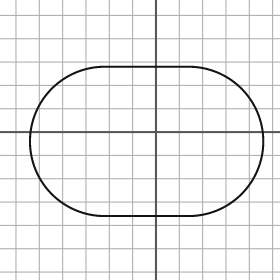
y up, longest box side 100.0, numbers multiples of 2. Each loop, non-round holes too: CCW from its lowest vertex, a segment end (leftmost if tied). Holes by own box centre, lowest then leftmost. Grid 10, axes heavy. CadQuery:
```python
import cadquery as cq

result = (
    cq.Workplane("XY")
    .moveTo(-22.0, -36.0)
    .lineTo(14.0, -36.0)
    .threePointArc((46.0, -4.0), (14.0, 28.0))
    .lineTo(-22.0, 28.0)
    .threePointArc((-54.0, -4.0), (-22.0, -36.0))
    .close()
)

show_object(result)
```